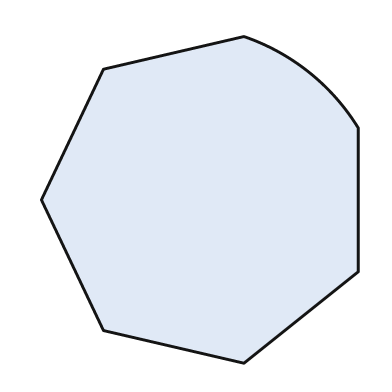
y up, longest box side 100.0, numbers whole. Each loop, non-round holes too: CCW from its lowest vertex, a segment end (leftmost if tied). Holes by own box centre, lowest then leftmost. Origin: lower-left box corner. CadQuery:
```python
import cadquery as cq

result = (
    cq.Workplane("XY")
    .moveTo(62.0, 0.0)
    .lineTo(97.0, 28.0)
    .lineTo(97.0, 72.0)
    .threePointArc((82.0, 89.0), (62.0, 100.0))
    .lineTo(19.0, 90.0)
    .lineTo(0.0, 50.0)
    .lineTo(19.0, 10.0)
    .close()
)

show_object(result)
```